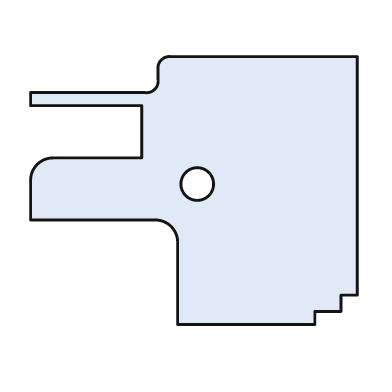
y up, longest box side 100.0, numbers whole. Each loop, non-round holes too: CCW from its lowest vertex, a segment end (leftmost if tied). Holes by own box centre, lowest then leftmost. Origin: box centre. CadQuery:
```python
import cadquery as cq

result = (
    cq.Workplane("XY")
    .moveTo(-5.0, -41.0)
    .lineTo(37.0, -41.0)
    .lineTo(37.0, -37.0)
    .lineTo(45.0, -37.0)
    .lineTo(45.0, -32.0)
    .lineTo(50.0, -32.0)
    .lineTo(50.0, 41.0)
    .lineTo(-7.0, 41.0)
    .threePointArc((-10.0, 40.0), (-11.0, 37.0))
    .lineTo(-11.0, 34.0)
    .threePointArc((-12.0, 31.0), (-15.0, 30.0))
    .lineTo(-50.0, 30.0)
    .lineTo(-50.0, 26.0)
    .lineTo(-16.0, 26.0)
    .lineTo(-16.0, 10.0)
    .lineTo(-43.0, 10.0)
    .threePointArc((-48.0, 8.0), (-50.0, 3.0))
    .lineTo(-50.0, -9.0)
    .lineTo(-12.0, -9.0)
    .threePointArc((-7.0, -11.0), (-5.0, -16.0))
    .close()
    .moveTo(1.0, 2.0)
    .circle(5.0)
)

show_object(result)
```